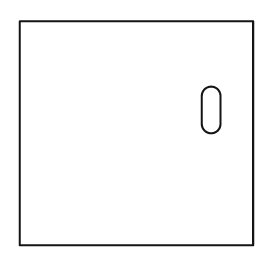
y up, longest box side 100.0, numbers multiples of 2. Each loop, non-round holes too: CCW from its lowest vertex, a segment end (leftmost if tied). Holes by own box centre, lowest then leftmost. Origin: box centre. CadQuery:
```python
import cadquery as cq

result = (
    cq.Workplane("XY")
    .moveTo(-50.0, -48.0)
    .lineTo(50.0, -48.0)
    .lineTo(50.0, 48.0)
    .lineTo(-50.0, 48.0)
    .close()
    .moveTo(28.0, 4.0)
    .threePointArc((32.0, 0.0), (36.0, 4.0))
    .lineTo(36.0, 16.0)
    .threePointArc((32.0, 20.0), (28.0, 16.0))
    .close()
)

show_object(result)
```